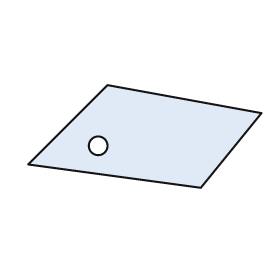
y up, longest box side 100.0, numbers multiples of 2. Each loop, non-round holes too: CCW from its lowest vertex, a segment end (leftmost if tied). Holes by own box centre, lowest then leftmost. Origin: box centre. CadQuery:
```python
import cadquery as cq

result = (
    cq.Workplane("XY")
    .moveTo(24.0, -22.0)
    .lineTo(50.0, 10.0)
    .lineTo(-16.0, 22.0)
    .lineTo(-50.0, -12.0)
    .close()
    .moveTo(-20.0, -4.0)
    .circle(4.0)
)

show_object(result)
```